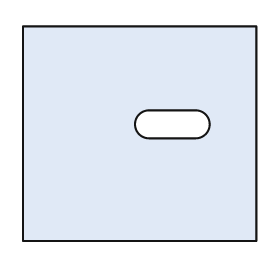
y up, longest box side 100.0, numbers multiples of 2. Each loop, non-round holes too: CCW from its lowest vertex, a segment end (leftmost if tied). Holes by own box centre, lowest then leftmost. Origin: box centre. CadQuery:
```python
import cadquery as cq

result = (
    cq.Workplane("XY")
    .moveTo(-50.0, -46.0)
    .lineTo(50.0, -46.0)
    .lineTo(50.0, 46.0)
    .lineTo(-50.0, 46.0)
    .close()
    .moveTo(4.0, -2.0)
    .lineTo(24.0, -2.0)
    .threePointArc((30.0, 4.0), (24.0, 10.0))
    .lineTo(4.0, 10.0)
    .threePointArc((-2.0, 4.0), (4.0, -2.0))
    .close()
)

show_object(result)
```